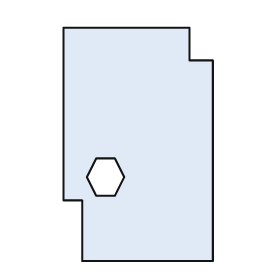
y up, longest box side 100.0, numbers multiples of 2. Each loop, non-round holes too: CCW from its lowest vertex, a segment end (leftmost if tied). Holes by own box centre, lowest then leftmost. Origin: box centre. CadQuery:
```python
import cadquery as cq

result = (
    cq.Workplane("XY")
    .moveTo(-24.0, -50.0)
    .lineTo(32.0, -50.0)
    .lineTo(32.0, 36.0)
    .lineTo(22.0, 36.0)
    .lineTo(22.0, 50.0)
    .lineTo(-32.0, 50.0)
    .lineTo(-32.0, -24.0)
    .lineTo(-24.0, -24.0)
    .close()
    .moveTo(-18.0, -22.0)
    .lineTo(-10.0, -22.0)
    .lineTo(-6.0, -14.0)
    .lineTo(-10.0, -6.0)
    .lineTo(-18.0, -6.0)
    .lineTo(-22.0, -14.0)
    .close()
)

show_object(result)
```